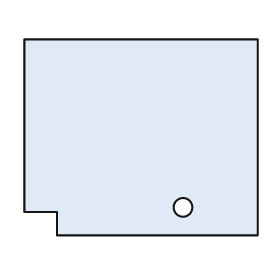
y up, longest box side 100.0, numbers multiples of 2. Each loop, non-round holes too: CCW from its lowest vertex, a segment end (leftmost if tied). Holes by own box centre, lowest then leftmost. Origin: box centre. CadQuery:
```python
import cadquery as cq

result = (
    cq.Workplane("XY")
    .moveTo(-36.0, -42.0)
    .lineTo(50.0, -42.0)
    .lineTo(50.0, 42.0)
    .lineTo(-50.0, 42.0)
    .lineTo(-50.0, -32.0)
    .lineTo(-36.0, -32.0)
    .close()
    .moveTo(18.0, -30.0)
    .circle(4.0)
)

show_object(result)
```